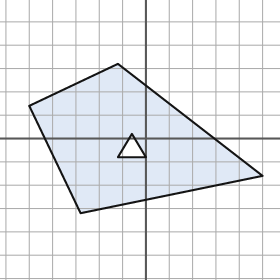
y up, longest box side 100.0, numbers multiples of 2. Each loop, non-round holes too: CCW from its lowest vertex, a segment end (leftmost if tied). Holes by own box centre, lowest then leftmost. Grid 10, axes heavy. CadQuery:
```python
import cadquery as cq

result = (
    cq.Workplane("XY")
    .moveTo(-28.0, -32.0)
    .lineTo(50.0, -16.0)
    .lineTo(-12.0, 32.0)
    .lineTo(-50.0, 14.0)
    .close()
    .moveTo(-12.0, -8.0)
    .lineTo(0.0, -8.0)
    .lineTo(-6.0, 2.0)
    .close()
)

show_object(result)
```